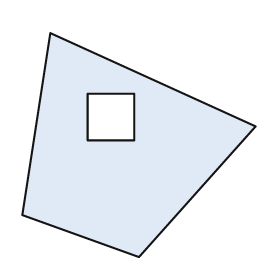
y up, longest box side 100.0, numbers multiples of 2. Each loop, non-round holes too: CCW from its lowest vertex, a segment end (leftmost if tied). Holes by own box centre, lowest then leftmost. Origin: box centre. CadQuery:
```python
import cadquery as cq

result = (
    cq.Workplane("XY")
    .moveTo(0.0, -48.0)
    .lineTo(50.0, 8.0)
    .lineTo(-38.0, 48.0)
    .lineTo(-50.0, -30.0)
    .close()
    .moveTo(-22.0, 2.0)
    .lineTo(-2.0, 2.0)
    .lineTo(-2.0, 22.0)
    .lineTo(-22.0, 22.0)
    .close()
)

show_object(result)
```